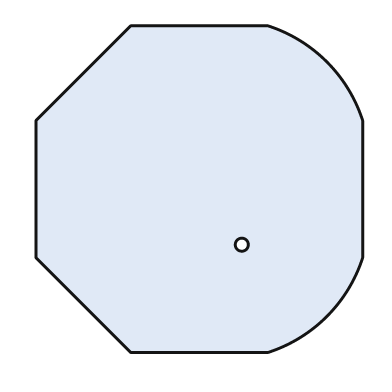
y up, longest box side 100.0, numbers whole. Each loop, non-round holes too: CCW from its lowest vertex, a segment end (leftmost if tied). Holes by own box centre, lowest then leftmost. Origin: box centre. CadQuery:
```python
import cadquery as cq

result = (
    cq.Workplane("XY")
    .moveTo(-21.0, -50.0)
    .lineTo(21.0, -50.0)
    .threePointArc((39.0, -39.0), (50.0, -21.0))
    .lineTo(50.0, 21.0)
    .threePointArc((39.0, 39.0), (21.0, 50.0))
    .lineTo(-21.0, 50.0)
    .lineTo(-50.0, 21.0)
    .lineTo(-50.0, -21.0)
    .close()
    .moveTo(13.0, -17.0)
    .circle(2.0)
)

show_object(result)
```